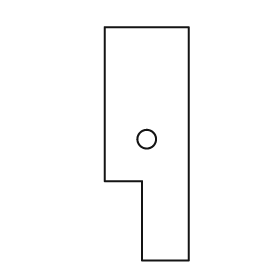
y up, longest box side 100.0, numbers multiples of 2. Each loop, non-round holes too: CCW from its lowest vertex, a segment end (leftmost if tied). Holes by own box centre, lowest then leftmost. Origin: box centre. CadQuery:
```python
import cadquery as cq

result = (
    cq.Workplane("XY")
    .moveTo(-2.0, -50.0)
    .lineTo(18.0, -50.0)
    .lineTo(18.0, 50.0)
    .lineTo(-18.0, 50.0)
    .lineTo(-18.0, -16.0)
    .lineTo(-2.0, -16.0)
    .close()
    .moveTo(0.0, 2.0)
    .circle(4.0)
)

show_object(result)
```